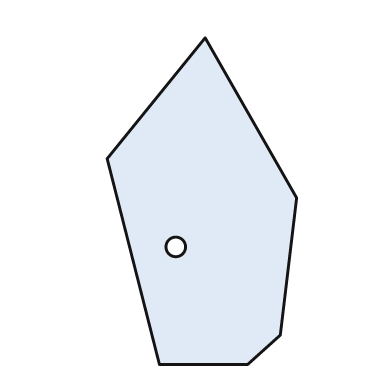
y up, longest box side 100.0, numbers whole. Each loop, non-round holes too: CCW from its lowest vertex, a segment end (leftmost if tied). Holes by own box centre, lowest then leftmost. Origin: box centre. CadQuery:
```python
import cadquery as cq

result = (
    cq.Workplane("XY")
    .moveTo(-13.0, -50.0)
    .lineTo(14.0, -50.0)
    .lineTo(24.0, -41.0)
    .lineTo(29.0, 1.0)
    .lineTo(1.0, 50.0)
    .lineTo(-29.0, 13.0)
    .close()
    .moveTo(-8.0, -14.0)
    .circle(3.0)
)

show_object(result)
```